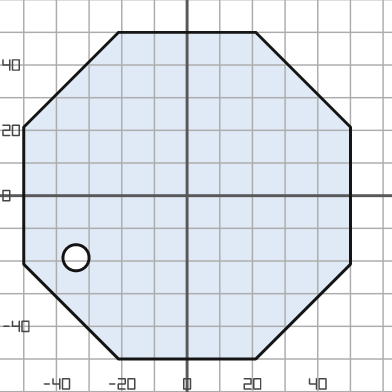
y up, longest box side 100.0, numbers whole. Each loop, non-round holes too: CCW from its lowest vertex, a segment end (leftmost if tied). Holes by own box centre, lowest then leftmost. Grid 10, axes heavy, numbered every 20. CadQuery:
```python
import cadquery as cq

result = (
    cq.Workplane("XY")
    .moveTo(-21.0, -50.0)
    .lineTo(21.0, -50.0)
    .lineTo(50.0, -21.0)
    .lineTo(50.0, 21.0)
    .lineTo(21.0, 50.0)
    .lineTo(-21.0, 50.0)
    .lineTo(-50.0, 21.0)
    .lineTo(-50.0, -21.0)
    .close()
    .moveTo(-34.0, -19.0)
    .circle(4.0)
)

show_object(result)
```